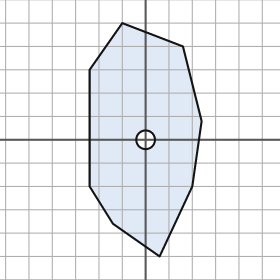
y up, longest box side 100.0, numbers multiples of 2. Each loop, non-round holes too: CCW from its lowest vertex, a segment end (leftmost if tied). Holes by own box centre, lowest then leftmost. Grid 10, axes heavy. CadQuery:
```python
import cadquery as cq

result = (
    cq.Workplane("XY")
    .moveTo(6.0, -50.0)
    .lineTo(20.0, -20.0)
    .lineTo(24.0, 8.0)
    .lineTo(16.0, 40.0)
    .lineTo(-10.0, 50.0)
    .lineTo(-24.0, 30.0)
    .lineTo(-24.0, -20.0)
    .lineTo(-14.0, -36.0)
    .close()
    .moveTo(0.0, 0.0)
    .circle(4.0)
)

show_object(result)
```